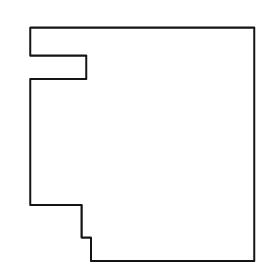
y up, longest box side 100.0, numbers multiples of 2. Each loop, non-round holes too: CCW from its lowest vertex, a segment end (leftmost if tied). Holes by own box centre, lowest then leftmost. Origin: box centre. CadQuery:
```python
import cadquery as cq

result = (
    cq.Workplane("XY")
    .moveTo(-22.0, -50.0)
    .lineTo(48.0, -50.0)
    .lineTo(48.0, 50.0)
    .lineTo(-48.0, 50.0)
    .lineTo(-48.0, 38.0)
    .lineTo(-24.0, 38.0)
    .lineTo(-24.0, 28.0)
    .lineTo(-48.0, 28.0)
    .lineTo(-48.0, -26.0)
    .lineTo(-26.0, -26.0)
    .lineTo(-26.0, -40.0)
    .lineTo(-22.0, -40.0)
    .close()
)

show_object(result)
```